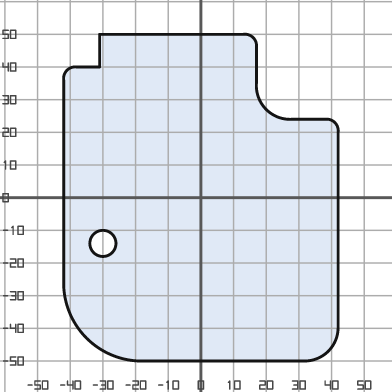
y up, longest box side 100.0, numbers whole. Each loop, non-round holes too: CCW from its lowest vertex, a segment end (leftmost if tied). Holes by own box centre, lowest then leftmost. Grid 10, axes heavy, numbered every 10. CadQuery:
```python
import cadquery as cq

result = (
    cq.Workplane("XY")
    .moveTo(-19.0, -50.0)
    .lineTo(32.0, -50.0)
    .threePointArc((39.0, -47.0), (42.0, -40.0))
    .lineTo(42.0, 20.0)
    .threePointArc((41.0, 23.0), (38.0, 24.0))
    .lineTo(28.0, 24.0)
    .threePointArc((20.0, 27.0), (17.0, 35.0))
    .lineTo(17.0, 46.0)
    .threePointArc((16.0, 49.0), (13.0, 50.0))
    .lineTo(-31.0, 50.0)
    .lineTo(-31.0, 40.0)
    .lineTo(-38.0, 40.0)
    .threePointArc((-41.0, 39.0), (-42.0, 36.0))
    .lineTo(-42.0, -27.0)
    .threePointArc((-35.0, -43.0), (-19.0, -50.0))
    .close()
    .moveTo(-30.0, -14.0)
    .circle(4.0)
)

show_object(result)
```